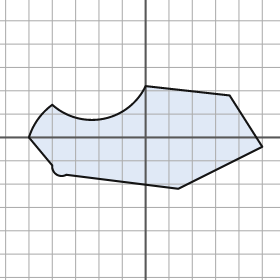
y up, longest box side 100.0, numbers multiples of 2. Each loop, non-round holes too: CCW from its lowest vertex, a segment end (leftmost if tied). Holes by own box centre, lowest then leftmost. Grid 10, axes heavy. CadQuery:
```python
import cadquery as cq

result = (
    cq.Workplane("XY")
    .moveTo(14.0, -22.0)
    .lineTo(50.0, -4.0)
    .lineTo(36.0, 18.0)
    .lineTo(0.0, 22.0)
    .threePointArc((-18.0, 8.0), (-40.0, 14.0))
    .threePointArc((-46.0, 8.0), (-50.0, 0.0))
    .lineTo(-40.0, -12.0)
    .threePointArc((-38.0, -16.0), (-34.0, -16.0))
    .close()
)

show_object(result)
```